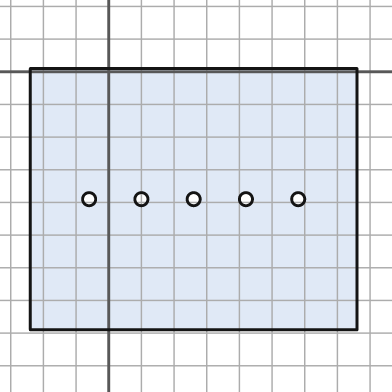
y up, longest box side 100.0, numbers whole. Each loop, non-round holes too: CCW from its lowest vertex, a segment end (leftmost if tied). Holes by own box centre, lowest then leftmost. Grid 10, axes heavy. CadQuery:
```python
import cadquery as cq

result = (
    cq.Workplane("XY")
    .moveTo(-24.0, -79.0)
    .lineTo(76.0, -79.0)
    .lineTo(76.0, 1.0)
    .lineTo(-24.0, 1.0)
    .close()
    .moveTo(-6.0, -39.0)
    .circle(2.0)
    .moveTo(10.0, -39.0)
    .circle(2.0)
    .moveTo(26.0, -39.0)
    .circle(2.0)
    .moveTo(42.0, -39.0)
    .circle(2.0)
    .moveTo(58.0, -39.0)
    .circle(2.0)
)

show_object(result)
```